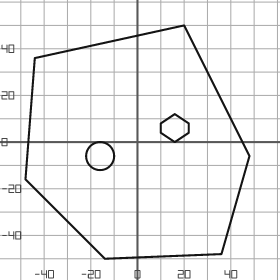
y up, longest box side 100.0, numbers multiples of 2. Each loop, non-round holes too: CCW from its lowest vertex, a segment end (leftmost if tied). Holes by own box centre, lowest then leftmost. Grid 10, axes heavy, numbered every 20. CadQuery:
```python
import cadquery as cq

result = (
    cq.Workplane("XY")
    .moveTo(-14.0, -50.0)
    .lineTo(36.0, -48.0)
    .lineTo(48.0, -6.0)
    .lineTo(20.0, 50.0)
    .lineTo(-44.0, 36.0)
    .lineTo(-48.0, -16.0)
    .close()
    .moveTo(-16.0, -6.0)
    .circle(6.0)
    .moveTo(16.0, 0.0)
    .lineTo(22.0, 4.0)
    .lineTo(22.0, 8.0)
    .lineTo(16.0, 12.0)
    .lineTo(10.0, 8.0)
    .lineTo(10.0, 4.0)
    .close()
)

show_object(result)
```